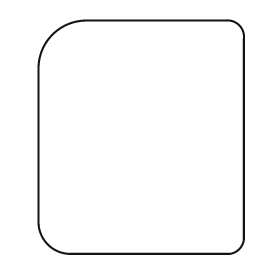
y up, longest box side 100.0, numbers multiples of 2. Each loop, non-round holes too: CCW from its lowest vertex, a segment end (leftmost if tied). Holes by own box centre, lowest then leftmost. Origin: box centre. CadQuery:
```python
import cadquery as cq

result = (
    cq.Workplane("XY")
    .moveTo(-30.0, -50.0)
    .lineTo(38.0, -50.0)
    .threePointArc((42.0, -48.0), (44.0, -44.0))
    .lineTo(44.0, 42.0)
    .threePointArc((42.0, 48.0), (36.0, 50.0))
    .lineTo(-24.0, 50.0)
    .threePointArc((-38.0, 44.0), (-44.0, 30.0))
    .lineTo(-44.0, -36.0)
    .threePointArc((-40.0, -46.0), (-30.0, -50.0))
    .close()
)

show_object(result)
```